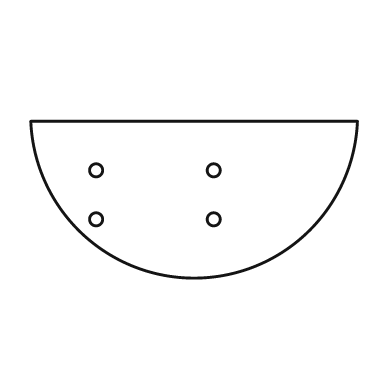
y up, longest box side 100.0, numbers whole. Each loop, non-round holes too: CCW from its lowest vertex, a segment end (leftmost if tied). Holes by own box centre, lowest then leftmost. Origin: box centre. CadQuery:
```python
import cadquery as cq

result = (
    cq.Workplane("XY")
    .moveTo(-50.0, 24.0)
    .threePointArc((0.0, -24.0), (50.0, 24.0))
    .close()
    .moveTo(-30.0, -6.0)
    .circle(2.0)
    .moveTo(6.0, -6.0)
    .circle(2.0)
    .moveTo(-30.0, 9.0)
    .circle(2.0)
    .moveTo(6.0, 9.0)
    .circle(2.0)
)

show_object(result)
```